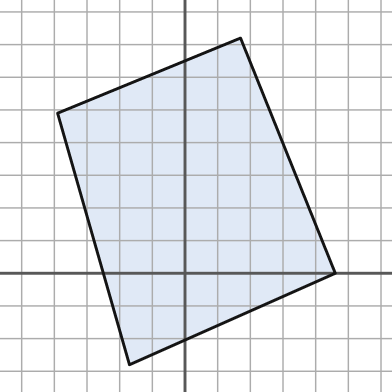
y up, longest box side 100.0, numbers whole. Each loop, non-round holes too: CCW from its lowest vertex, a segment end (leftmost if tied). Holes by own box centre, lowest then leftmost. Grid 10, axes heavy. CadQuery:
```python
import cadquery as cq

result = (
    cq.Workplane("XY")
    .moveTo(-17.0, -28.0)
    .lineTo(46.0, 0.0)
    .lineTo(17.0, 72.0)
    .lineTo(-39.0, 49.0)
    .close()
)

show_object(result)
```